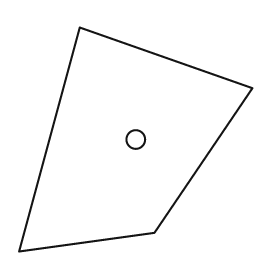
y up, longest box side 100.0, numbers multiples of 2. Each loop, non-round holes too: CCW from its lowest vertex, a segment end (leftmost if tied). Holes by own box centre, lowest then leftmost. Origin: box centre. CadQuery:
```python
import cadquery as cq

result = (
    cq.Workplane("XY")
    .moveTo(-50.0, -48.0)
    .lineTo(8.0, -40.0)
    .lineTo(50.0, 22.0)
    .lineTo(-24.0, 48.0)
    .close()
    .moveTo(0.0, 0.0)
    .circle(4.0)
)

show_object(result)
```